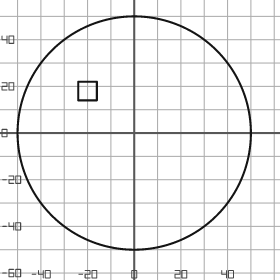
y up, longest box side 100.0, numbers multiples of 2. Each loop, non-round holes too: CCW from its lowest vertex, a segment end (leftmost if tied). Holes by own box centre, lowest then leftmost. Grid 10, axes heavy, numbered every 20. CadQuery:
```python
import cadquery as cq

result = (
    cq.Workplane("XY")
    .moveTo(0.0, 0.0)
    .circle(50.0)
    .moveTo(-24.0, 14.0)
    .lineTo(-16.0, 14.0)
    .lineTo(-16.0, 22.0)
    .lineTo(-24.0, 22.0)
    .close()
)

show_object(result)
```